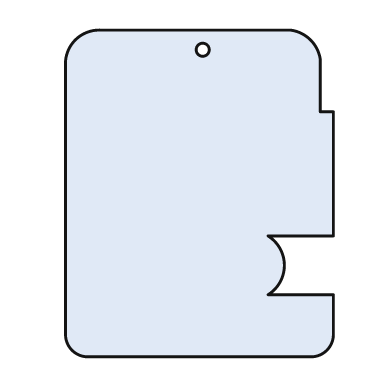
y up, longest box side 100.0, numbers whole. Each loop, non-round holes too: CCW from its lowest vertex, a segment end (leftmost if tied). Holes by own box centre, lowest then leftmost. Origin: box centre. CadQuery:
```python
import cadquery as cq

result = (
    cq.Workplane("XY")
    .moveTo(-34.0, -50.0)
    .lineTo(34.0, -50.0)
    .threePointArc((39.0, -48.0), (41.0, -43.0))
    .lineTo(41.0, -31.0)
    .lineTo(21.0, -31.0)
    .threePointArc((26.0, -22.0), (21.0, -13.0))
    .lineTo(41.0, -13.0)
    .lineTo(41.0, 25.0)
    .lineTo(37.0, 25.0)
    .lineTo(37.0, 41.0)
    .threePointArc((34.0, 47.0), (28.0, 50.0))
    .lineTo(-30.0, 50.0)
    .threePointArc((-38.0, 47.0), (-41.0, 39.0))
    .lineTo(-41.0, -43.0)
    .threePointArc((-39.0, -48.0), (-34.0, -50.0))
    .close()
    .moveTo(1.0, 44.0)
    .circle(2.0)
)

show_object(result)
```